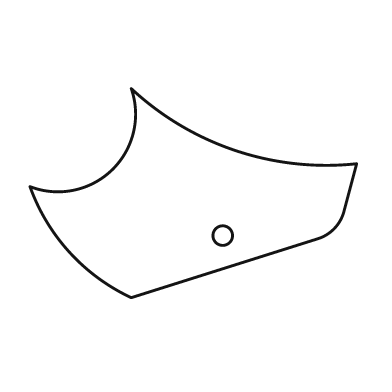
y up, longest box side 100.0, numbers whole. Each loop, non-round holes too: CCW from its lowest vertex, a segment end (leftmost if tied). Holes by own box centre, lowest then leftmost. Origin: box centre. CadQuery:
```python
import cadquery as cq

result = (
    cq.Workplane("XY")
    .moveTo(-19.0, -32.0)
    .lineTo(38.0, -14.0)
    .threePointArc((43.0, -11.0), (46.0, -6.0))
    .lineTo(50.0, 9.0)
    .threePointArc((13.0, 13.0), (-19.0, 32.0))
    .threePointArc((-25.0, 7.0), (-50.0, 2.0))
    .threePointArc((-38.0, -18.0), (-19.0, -32.0))
    .close()
    .moveTo(9.0, -13.0)
    .circle(3.0)
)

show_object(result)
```